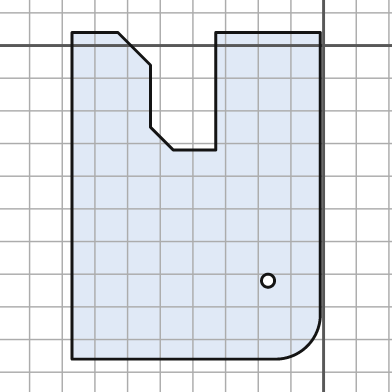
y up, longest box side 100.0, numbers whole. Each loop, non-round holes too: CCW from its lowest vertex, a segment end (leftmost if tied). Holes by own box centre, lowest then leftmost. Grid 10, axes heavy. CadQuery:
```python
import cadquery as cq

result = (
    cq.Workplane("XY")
    .moveTo(-77.0, -96.0)
    .lineTo(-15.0, -96.0)
    .threePointArc((-5.0, -92.0), (-1.0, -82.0))
    .lineTo(-1.0, 4.0)
    .lineTo(-33.0, 4.0)
    .lineTo(-33.0, -32.0)
    .lineTo(-46.0, -32.0)
    .lineTo(-53.0, -25.0)
    .lineTo(-53.0, -6.0)
    .lineTo(-63.0, 4.0)
    .lineTo(-77.0, 4.0)
    .close()
    .moveTo(-17.0, -72.0)
    .circle(2.0)
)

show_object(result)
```